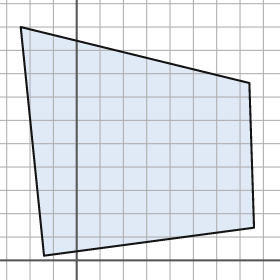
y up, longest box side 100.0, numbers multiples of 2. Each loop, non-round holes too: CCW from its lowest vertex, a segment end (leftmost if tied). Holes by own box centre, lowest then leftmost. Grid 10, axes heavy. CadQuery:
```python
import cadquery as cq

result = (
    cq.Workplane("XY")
    .moveTo(-14.0, 2.0)
    .lineTo(76.0, 14.0)
    .lineTo(74.0, 76.0)
    .lineTo(-24.0, 100.0)
    .close()
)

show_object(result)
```